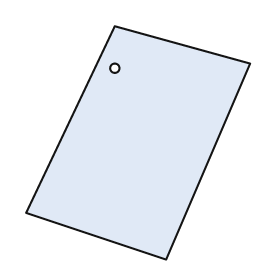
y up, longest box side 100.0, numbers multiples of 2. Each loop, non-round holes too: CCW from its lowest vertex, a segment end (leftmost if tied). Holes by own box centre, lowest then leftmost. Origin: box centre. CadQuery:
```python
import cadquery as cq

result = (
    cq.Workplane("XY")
    .moveTo(12.0, -50.0)
    .lineTo(48.0, 34.0)
    .lineTo(-10.0, 50.0)
    .lineTo(-48.0, -30.0)
    .close()
    .moveTo(-10.0, 32.0)
    .circle(2.0)
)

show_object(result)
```